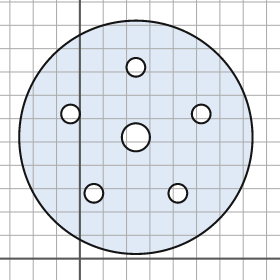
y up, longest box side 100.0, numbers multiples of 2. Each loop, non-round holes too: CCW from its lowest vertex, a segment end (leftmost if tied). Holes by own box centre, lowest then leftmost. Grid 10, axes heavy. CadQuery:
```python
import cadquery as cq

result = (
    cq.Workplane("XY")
    .moveTo(24.0, 52.0)
    .circle(50.0)
    .moveTo(6.0, 28.0)
    .circle(4.0)
    .moveTo(42.0, 28.0)
    .circle(4.0)
    .moveTo(24.0, 52.0)
    .circle(6.0)
    .moveTo(-4.0, 62.0)
    .circle(4.0)
    .moveTo(52.0, 62.0)
    .circle(4.0)
    .moveTo(24.0, 82.0)
    .circle(4.0)
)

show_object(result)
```